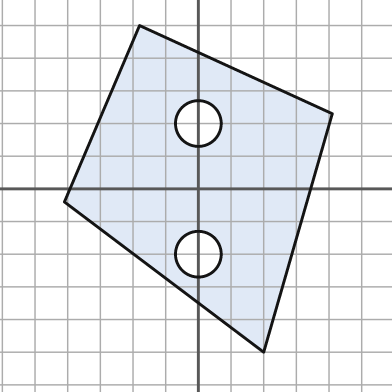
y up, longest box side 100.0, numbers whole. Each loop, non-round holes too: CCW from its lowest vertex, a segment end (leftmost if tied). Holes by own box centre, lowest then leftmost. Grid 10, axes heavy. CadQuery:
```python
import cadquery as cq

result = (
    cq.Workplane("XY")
    .moveTo(20.0, -50.0)
    .lineTo(41.0, 23.0)
    .lineTo(-18.0, 50.0)
    .lineTo(-41.0, -4.0)
    .close()
    .moveTo(0.0, -20.0)
    .circle(7.0)
    .moveTo(0.0, 20.0)
    .circle(7.0)
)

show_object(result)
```